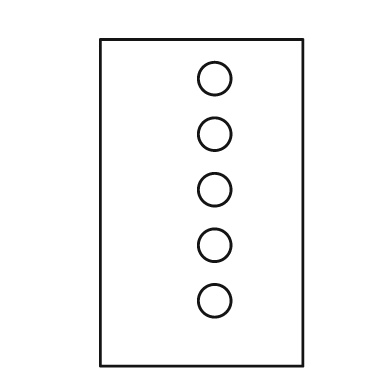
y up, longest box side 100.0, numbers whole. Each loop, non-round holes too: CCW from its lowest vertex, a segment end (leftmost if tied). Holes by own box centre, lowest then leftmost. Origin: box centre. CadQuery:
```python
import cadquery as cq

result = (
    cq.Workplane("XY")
    .moveTo(-31.0, -50.0)
    .lineTo(31.0, -50.0)
    .lineTo(31.0, 50.0)
    .lineTo(-31.0, 50.0)
    .close()
    .moveTo(4.0, -30.0)
    .circle(5.0)
    .moveTo(4.0, -13.0)
    .circle(5.0)
    .moveTo(4.0, 4.0)
    .circle(5.0)
    .moveTo(4.0, 21.0)
    .circle(5.0)
    .moveTo(4.0, 38.0)
    .circle(5.0)
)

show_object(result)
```